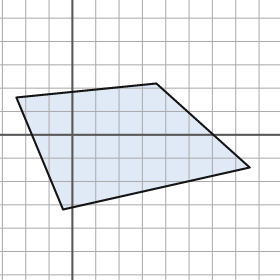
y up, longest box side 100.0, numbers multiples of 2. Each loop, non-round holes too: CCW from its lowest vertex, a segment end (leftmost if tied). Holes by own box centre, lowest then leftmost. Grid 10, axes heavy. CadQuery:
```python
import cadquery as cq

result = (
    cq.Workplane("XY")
    .moveTo(-4.0, -32.0)
    .lineTo(76.0, -14.0)
    .lineTo(36.0, 22.0)
    .lineTo(-24.0, 16.0)
    .close()
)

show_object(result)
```